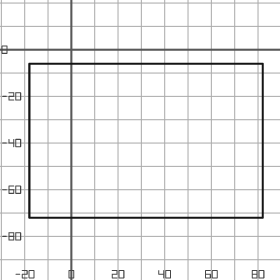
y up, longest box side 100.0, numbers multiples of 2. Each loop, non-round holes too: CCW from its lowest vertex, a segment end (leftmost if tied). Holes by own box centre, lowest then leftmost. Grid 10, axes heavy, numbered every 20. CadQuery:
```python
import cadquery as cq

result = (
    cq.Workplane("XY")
    .moveTo(-18.0, -72.0)
    .lineTo(82.0, -72.0)
    .lineTo(82.0, -6.0)
    .lineTo(-18.0, -6.0)
    .close()
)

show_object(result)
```